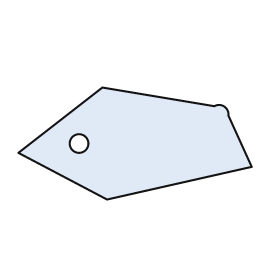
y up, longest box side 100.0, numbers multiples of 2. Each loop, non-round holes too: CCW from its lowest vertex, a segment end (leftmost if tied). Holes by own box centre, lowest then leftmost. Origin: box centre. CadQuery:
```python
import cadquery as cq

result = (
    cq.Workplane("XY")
    .moveTo(-12.0, -24.0)
    .lineTo(50.0, -10.0)
    .lineTo(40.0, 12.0)
    .threePointArc((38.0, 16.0), (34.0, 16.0))
    .lineTo(-14.0, 24.0)
    .lineTo(-50.0, -4.0)
    .close()
    .moveTo(-24.0, 0.0)
    .circle(4.0)
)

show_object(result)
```